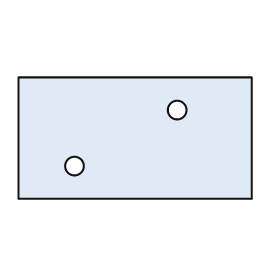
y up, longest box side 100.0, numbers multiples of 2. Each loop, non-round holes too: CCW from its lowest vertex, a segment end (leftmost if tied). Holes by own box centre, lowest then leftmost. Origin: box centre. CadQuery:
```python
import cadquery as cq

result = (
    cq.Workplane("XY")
    .moveTo(-50.0, -26.0)
    .lineTo(50.0, -26.0)
    .lineTo(50.0, 26.0)
    .lineTo(-50.0, 26.0)
    .close()
    .moveTo(-26.0, -12.0)
    .circle(4.0)
    .moveTo(18.0, 12.0)
    .circle(4.0)
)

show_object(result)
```